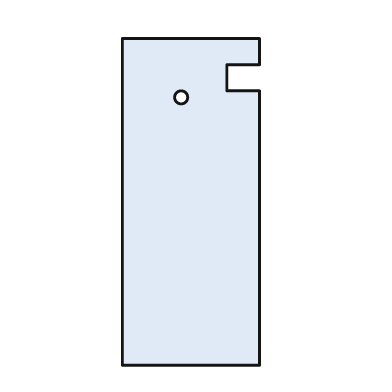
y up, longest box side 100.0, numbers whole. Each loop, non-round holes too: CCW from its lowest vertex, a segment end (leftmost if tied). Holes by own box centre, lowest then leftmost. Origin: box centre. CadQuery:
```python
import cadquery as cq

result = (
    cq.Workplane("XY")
    .moveTo(-21.0, -50.0)
    .lineTo(21.0, -50.0)
    .lineTo(21.0, 34.0)
    .lineTo(11.0, 34.0)
    .lineTo(11.0, 42.0)
    .lineTo(21.0, 42.0)
    .lineTo(21.0, 50.0)
    .lineTo(-21.0, 50.0)
    .close()
    .moveTo(-3.0, 32.0)
    .circle(2.0)
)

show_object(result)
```